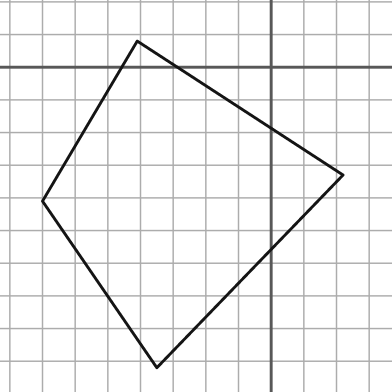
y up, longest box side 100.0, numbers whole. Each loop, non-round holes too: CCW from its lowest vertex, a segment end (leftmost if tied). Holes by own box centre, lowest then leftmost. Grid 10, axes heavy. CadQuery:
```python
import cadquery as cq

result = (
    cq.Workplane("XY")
    .moveTo(-35.0, -92.0)
    .lineTo(22.0, -33.0)
    .lineTo(-41.0, 8.0)
    .lineTo(-70.0, -41.0)
    .close()
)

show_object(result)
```